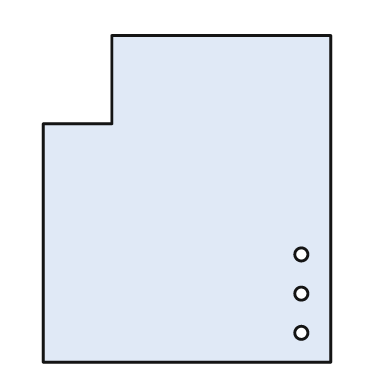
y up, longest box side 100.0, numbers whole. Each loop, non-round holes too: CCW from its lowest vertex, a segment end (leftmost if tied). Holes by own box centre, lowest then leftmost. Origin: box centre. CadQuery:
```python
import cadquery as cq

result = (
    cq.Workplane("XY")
    .moveTo(-44.0, -50.0)
    .lineTo(44.0, -50.0)
    .lineTo(44.0, 50.0)
    .lineTo(-23.0, 50.0)
    .lineTo(-23.0, 23.0)
    .lineTo(-44.0, 23.0)
    .close()
    .moveTo(35.0, -41.0)
    .circle(2.0)
    .moveTo(35.0, -29.0)
    .circle(2.0)
    .moveTo(35.0, -17.0)
    .circle(2.0)
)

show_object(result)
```